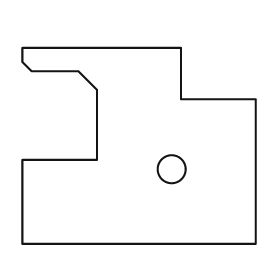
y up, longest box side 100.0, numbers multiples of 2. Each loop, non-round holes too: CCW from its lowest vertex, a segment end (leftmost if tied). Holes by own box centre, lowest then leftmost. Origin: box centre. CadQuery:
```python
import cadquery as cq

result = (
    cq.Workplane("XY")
    .moveTo(-50.0, -42.0)
    .lineTo(50.0, -42.0)
    .lineTo(50.0, 20.0)
    .lineTo(18.0, 20.0)
    .lineTo(18.0, 42.0)
    .lineTo(-50.0, 42.0)
    .lineTo(-50.0, 36.0)
    .lineTo(-46.0, 32.0)
    .lineTo(-26.0, 32.0)
    .lineTo(-18.0, 24.0)
    .lineTo(-18.0, -6.0)
    .lineTo(-50.0, -6.0)
    .close()
    .moveTo(14.0, -10.0)
    .circle(6.0)
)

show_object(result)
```